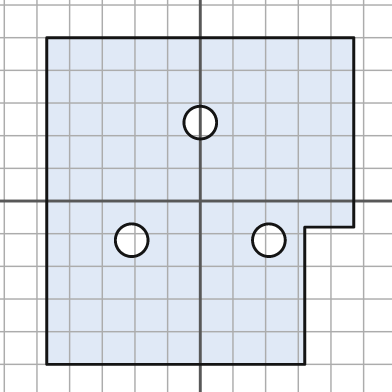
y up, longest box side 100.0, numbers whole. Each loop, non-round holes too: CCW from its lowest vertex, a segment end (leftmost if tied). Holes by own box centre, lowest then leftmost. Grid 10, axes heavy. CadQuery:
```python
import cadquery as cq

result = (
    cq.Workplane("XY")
    .moveTo(-47.0, -50.0)
    .lineTo(32.0, -50.0)
    .lineTo(32.0, -8.0)
    .lineTo(47.0, -8.0)
    .lineTo(47.0, 50.0)
    .lineTo(-47.0, 50.0)
    .close()
    .moveTo(-21.0, -12.0)
    .circle(5.0)
    .moveTo(21.0, -12.0)
    .circle(5.0)
    .moveTo(0.0, 24.0)
    .circle(5.0)
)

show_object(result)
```